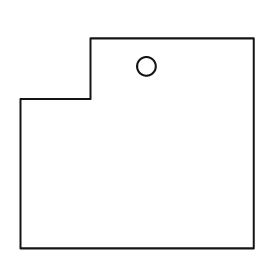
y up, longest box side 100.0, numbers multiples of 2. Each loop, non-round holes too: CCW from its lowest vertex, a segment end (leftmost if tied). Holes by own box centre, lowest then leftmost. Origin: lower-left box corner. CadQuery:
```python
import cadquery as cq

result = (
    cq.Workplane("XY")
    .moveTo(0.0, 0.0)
    .lineTo(100.0, 0.0)
    .lineTo(100.0, 90.0)
    .lineTo(30.0, 90.0)
    .lineTo(30.0, 64.0)
    .lineTo(0.0, 64.0)
    .close()
    .moveTo(54.0, 78.0)
    .circle(4.0)
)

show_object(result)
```